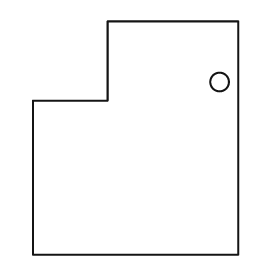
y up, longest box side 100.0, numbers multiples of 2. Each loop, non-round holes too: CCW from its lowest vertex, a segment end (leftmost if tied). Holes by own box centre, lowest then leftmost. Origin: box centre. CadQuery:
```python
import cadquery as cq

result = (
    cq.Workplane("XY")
    .moveTo(-44.0, -50.0)
    .lineTo(44.0, -50.0)
    .lineTo(44.0, 50.0)
    .lineTo(-12.0, 50.0)
    .lineTo(-12.0, 16.0)
    .lineTo(-44.0, 16.0)
    .close()
    .moveTo(36.0, 24.0)
    .circle(4.0)
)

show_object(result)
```